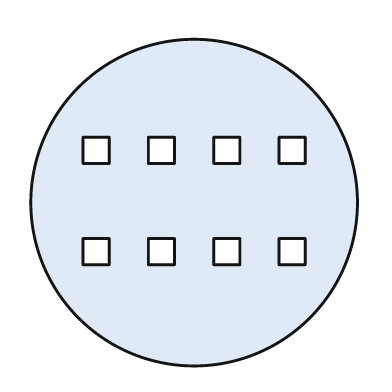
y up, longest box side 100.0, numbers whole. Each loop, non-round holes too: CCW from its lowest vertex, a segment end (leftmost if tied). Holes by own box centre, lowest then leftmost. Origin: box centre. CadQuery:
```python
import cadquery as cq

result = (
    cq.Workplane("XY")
    .moveTo(0.0, 0.0)
    .circle(50.0)
    .moveTo(-34.0, -19.0)
    .lineTo(-26.0, -19.0)
    .lineTo(-26.0, -11.0)
    .lineTo(-34.0, -11.0)
    .close()
    .moveTo(-14.0, -19.0)
    .lineTo(-6.0, -19.0)
    .lineTo(-6.0, -11.0)
    .lineTo(-14.0, -11.0)
    .close()
    .moveTo(6.0, -19.0)
    .lineTo(14.0, -19.0)
    .lineTo(14.0, -11.0)
    .lineTo(6.0, -11.0)
    .close()
    .moveTo(26.0, -19.0)
    .lineTo(34.0, -19.0)
    .lineTo(34.0, -11.0)
    .lineTo(26.0, -11.0)
    .close()
    .moveTo(-34.0, 12.0)
    .lineTo(-26.0, 12.0)
    .lineTo(-26.0, 20.0)
    .lineTo(-34.0, 20.0)
    .close()
    .moveTo(-14.0, 12.0)
    .lineTo(-6.0, 12.0)
    .lineTo(-6.0, 20.0)
    .lineTo(-14.0, 20.0)
    .close()
    .moveTo(6.0, 12.0)
    .lineTo(14.0, 12.0)
    .lineTo(14.0, 20.0)
    .lineTo(6.0, 20.0)
    .close()
    .moveTo(26.0, 12.0)
    .lineTo(34.0, 12.0)
    .lineTo(34.0, 20.0)
    .lineTo(26.0, 20.0)
    .close()
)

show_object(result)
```